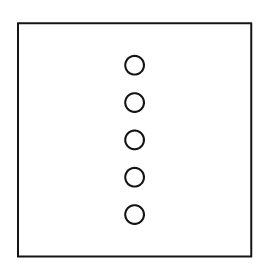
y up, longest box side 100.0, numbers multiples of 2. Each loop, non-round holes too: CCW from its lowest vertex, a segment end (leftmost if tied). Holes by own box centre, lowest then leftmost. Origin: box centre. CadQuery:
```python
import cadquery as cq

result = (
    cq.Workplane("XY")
    .moveTo(-50.0, -50.0)
    .lineTo(50.0, -50.0)
    .lineTo(50.0, 50.0)
    .lineTo(-50.0, 50.0)
    .close()
    .moveTo(0.0, -32.0)
    .circle(4.0)
    .moveTo(0.0, -16.0)
    .circle(4.0)
    .moveTo(0.0, 0.0)
    .circle(4.0)
    .moveTo(0.0, 16.0)
    .circle(4.0)
    .moveTo(0.0, 32.0)
    .circle(4.0)
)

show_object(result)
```